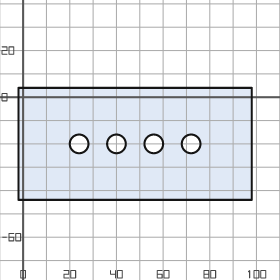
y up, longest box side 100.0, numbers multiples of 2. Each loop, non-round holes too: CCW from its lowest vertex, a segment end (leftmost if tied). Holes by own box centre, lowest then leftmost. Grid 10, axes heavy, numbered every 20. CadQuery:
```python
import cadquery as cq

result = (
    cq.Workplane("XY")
    .moveTo(-2.0, -44.0)
    .lineTo(98.0, -44.0)
    .lineTo(98.0, 4.0)
    .lineTo(-2.0, 4.0)
    .close()
    .moveTo(24.0, -20.0)
    .circle(4.0)
    .moveTo(40.0, -20.0)
    .circle(4.0)
    .moveTo(56.0, -20.0)
    .circle(4.0)
    .moveTo(72.0, -20.0)
    .circle(4.0)
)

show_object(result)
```